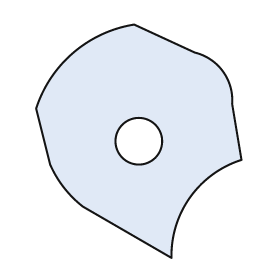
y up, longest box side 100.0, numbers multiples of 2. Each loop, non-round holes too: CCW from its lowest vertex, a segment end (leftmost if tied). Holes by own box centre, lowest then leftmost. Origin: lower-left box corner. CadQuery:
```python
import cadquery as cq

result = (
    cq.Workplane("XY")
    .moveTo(58.0, 0.0)
    .threePointArc((66.0, 26.0), (88.0, 42.0))
    .lineTo(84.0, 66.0)
    .threePointArc((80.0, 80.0), (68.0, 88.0))
    .lineTo(42.0, 100.0)
    .threePointArc((16.0, 88.0), (0.0, 64.0))
    .lineTo(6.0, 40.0)
    .threePointArc((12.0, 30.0), (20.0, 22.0))
    .close()
    .moveTo(44.0, 50.0)
    .circle(10.0)
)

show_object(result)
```